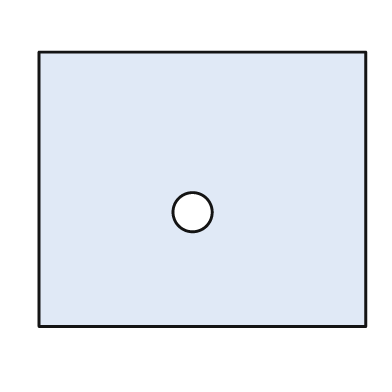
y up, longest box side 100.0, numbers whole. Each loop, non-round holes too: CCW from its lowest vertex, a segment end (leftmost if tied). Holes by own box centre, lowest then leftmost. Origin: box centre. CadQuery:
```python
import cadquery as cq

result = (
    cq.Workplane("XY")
    .moveTo(-50.0, -42.0)
    .lineTo(50.0, -42.0)
    .lineTo(50.0, 42.0)
    .lineTo(-50.0, 42.0)
    .close()
    .moveTo(-3.0, -7.0)
    .circle(6.0)
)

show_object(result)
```